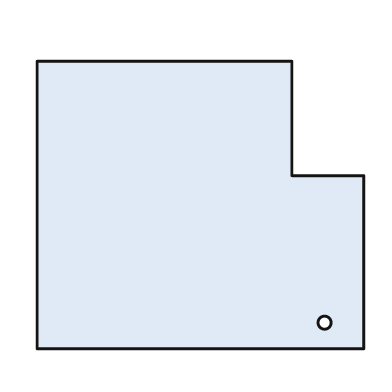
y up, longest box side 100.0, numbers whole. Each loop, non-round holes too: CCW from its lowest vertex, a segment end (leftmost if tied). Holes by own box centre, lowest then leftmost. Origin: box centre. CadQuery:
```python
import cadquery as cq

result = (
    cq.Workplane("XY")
    .moveTo(-50.0, -44.0)
    .lineTo(50.0, -44.0)
    .lineTo(50.0, 9.0)
    .lineTo(28.0, 9.0)
    .lineTo(28.0, 44.0)
    .lineTo(-50.0, 44.0)
    .close()
    .moveTo(38.0, -36.0)
    .circle(2.0)
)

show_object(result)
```